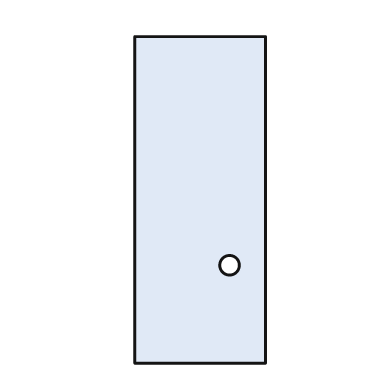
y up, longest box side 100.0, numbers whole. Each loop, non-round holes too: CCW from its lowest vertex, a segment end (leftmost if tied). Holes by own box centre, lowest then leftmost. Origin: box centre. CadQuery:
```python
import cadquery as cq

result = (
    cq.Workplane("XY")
    .moveTo(-20.0, -50.0)
    .lineTo(20.0, -50.0)
    .lineTo(20.0, 50.0)
    .lineTo(-20.0, 50.0)
    .close()
    .moveTo(9.0, -20.0)
    .circle(3.0)
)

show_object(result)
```